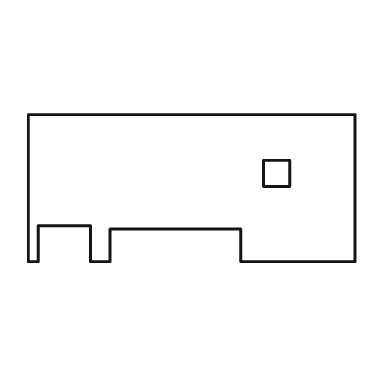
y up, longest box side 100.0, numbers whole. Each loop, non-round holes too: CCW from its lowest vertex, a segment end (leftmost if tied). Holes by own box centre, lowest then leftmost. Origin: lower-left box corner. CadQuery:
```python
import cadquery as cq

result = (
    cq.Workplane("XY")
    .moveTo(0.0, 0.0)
    .lineTo(3.0, 0.0)
    .lineTo(3.0, 11.0)
    .lineTo(19.0, 11.0)
    .lineTo(19.0, 0.0)
    .lineTo(25.0, 0.0)
    .lineTo(25.0, 10.0)
    .lineTo(65.0, 10.0)
    .lineTo(65.0, 0.0)
    .lineTo(100.0, 0.0)
    .lineTo(100.0, 45.0)
    .lineTo(0.0, 45.0)
    .close()
    .moveTo(72.0, 23.0)
    .lineTo(80.0, 23.0)
    .lineTo(80.0, 31.0)
    .lineTo(72.0, 31.0)
    .close()
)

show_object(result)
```